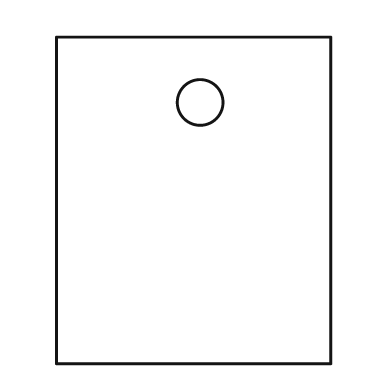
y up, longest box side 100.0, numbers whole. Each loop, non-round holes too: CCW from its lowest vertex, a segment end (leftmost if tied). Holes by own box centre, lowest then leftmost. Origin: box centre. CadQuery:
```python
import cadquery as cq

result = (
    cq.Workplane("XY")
    .moveTo(-42.0, -50.0)
    .lineTo(42.0, -50.0)
    .lineTo(42.0, 50.0)
    .lineTo(-42.0, 50.0)
    .close()
    .moveTo(2.0, 30.0)
    .circle(7.0)
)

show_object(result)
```